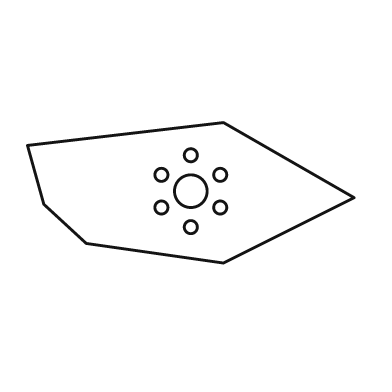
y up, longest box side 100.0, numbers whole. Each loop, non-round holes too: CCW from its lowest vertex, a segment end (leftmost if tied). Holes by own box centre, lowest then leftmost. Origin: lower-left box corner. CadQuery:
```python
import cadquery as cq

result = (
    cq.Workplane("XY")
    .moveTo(60.0, 0.0)
    .lineTo(100.0, 20.0)
    .lineTo(60.0, 43.0)
    .lineTo(0.0, 36.0)
    .lineTo(5.0, 18.0)
    .lineTo(18.0, 6.0)
    .close()
    .moveTo(50.0, 11.0)
    .circle(2.0)
    .moveTo(41.0, 17.0)
    .circle(2.0)
    .moveTo(59.0, 17.0)
    .circle(2.0)
    .moveTo(50.0, 22.0)
    .circle(5.0)
    .moveTo(41.0, 27.0)
    .circle(2.0)
    .moveTo(59.0, 27.0)
    .circle(2.0)
    .moveTo(50.0, 33.0)
    .circle(2.0)
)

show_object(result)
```